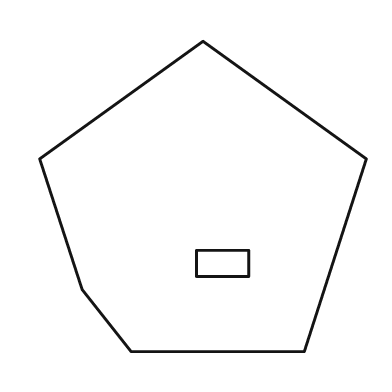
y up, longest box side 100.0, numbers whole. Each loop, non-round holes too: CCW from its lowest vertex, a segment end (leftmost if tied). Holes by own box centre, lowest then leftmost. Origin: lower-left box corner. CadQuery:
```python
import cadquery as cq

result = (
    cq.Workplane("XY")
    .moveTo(28.0, 0.0)
    .lineTo(81.0, 0.0)
    .lineTo(100.0, 59.0)
    .lineTo(50.0, 95.0)
    .lineTo(0.0, 59.0)
    .lineTo(13.0, 19.0)
    .close()
    .moveTo(48.0, 23.0)
    .lineTo(64.0, 23.0)
    .lineTo(64.0, 31.0)
    .lineTo(48.0, 31.0)
    .close()
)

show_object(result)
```